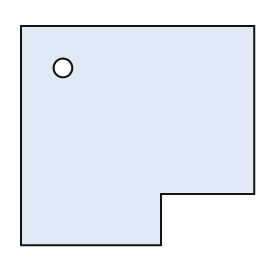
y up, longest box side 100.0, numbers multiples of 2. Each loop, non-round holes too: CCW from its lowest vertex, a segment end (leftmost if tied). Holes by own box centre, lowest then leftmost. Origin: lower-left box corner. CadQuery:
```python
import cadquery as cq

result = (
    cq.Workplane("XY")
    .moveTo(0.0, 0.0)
    .lineTo(60.0, 0.0)
    .lineTo(60.0, 22.0)
    .lineTo(100.0, 22.0)
    .lineTo(100.0, 94.0)
    .lineTo(0.0, 94.0)
    .close()
    .moveTo(18.0, 76.0)
    .circle(4.0)
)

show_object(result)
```